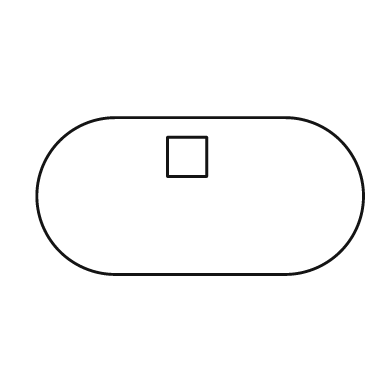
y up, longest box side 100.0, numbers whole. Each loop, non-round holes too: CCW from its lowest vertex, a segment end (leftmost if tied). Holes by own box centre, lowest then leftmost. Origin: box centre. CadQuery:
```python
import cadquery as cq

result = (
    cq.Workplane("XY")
    .moveTo(-26.0, -24.0)
    .lineTo(26.0, -24.0)
    .threePointArc((50.0, 0.0), (26.0, 24.0))
    .lineTo(-26.0, 24.0)
    .threePointArc((-50.0, 0.0), (-26.0, -24.0))
    .close()
    .moveTo(-10.0, 6.0)
    .lineTo(2.0, 6.0)
    .lineTo(2.0, 18.0)
    .lineTo(-10.0, 18.0)
    .close()
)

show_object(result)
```